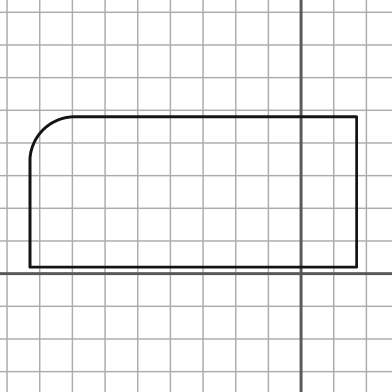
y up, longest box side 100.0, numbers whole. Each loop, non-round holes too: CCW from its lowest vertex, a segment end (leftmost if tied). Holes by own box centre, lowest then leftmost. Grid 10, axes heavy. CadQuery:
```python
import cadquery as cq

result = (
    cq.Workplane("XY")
    .moveTo(-83.0, 2.0)
    .lineTo(17.0, 2.0)
    .lineTo(17.0, 48.0)
    .lineTo(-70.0, 48.0)
    .threePointArc((-79.0, 44.0), (-83.0, 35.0))
    .close()
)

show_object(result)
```